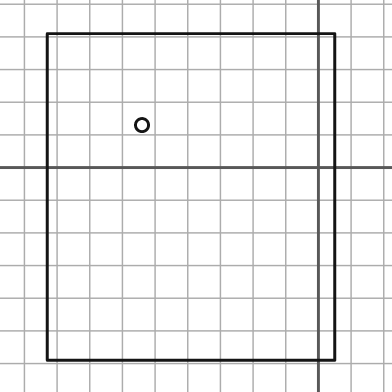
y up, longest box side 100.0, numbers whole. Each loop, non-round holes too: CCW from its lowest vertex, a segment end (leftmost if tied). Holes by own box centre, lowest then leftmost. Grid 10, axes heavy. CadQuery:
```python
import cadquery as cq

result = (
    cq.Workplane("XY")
    .moveTo(-83.0, -59.0)
    .lineTo(5.0, -59.0)
    .lineTo(5.0, 41.0)
    .lineTo(-83.0, 41.0)
    .close()
    .moveTo(-54.0, 13.0)
    .circle(2.0)
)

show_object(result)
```